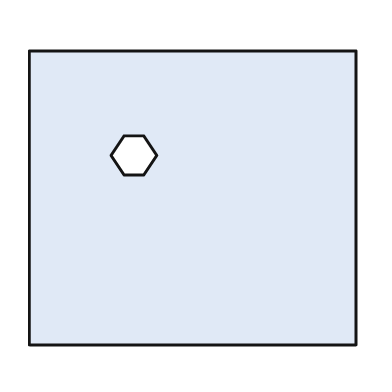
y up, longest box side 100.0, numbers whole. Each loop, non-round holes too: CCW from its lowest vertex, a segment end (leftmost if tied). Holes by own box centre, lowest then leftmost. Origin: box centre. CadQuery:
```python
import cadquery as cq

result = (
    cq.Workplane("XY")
    .moveTo(-50.0, -45.0)
    .lineTo(50.0, -45.0)
    .lineTo(50.0, 45.0)
    .lineTo(-50.0, 45.0)
    .close()
    .moveTo(-21.0, 7.0)
    .lineTo(-15.0, 7.0)
    .lineTo(-11.0, 13.0)
    .lineTo(-15.0, 19.0)
    .lineTo(-21.0, 19.0)
    .lineTo(-25.0, 13.0)
    .close()
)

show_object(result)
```